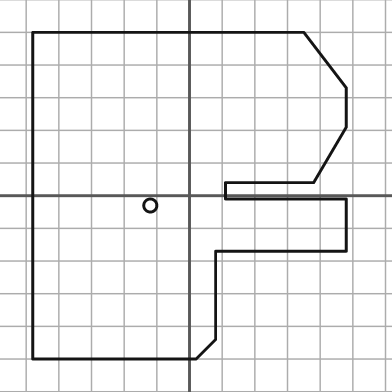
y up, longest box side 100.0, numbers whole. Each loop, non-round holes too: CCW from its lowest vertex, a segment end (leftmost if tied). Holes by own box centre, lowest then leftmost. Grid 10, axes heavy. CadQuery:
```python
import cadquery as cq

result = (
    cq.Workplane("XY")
    .moveTo(-48.0, -50.0)
    .lineTo(2.0, -50.0)
    .lineTo(8.0, -44.0)
    .lineTo(8.0, -17.0)
    .lineTo(48.0, -17.0)
    .lineTo(48.0, -1.0)
    .lineTo(11.0, -1.0)
    .lineTo(11.0, 4.0)
    .lineTo(38.0, 4.0)
    .lineTo(48.0, 21.0)
    .lineTo(48.0, 33.0)
    .lineTo(35.0, 50.0)
    .lineTo(-48.0, 50.0)
    .close()
    .moveTo(-12.0, -3.0)
    .circle(2.0)
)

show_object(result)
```